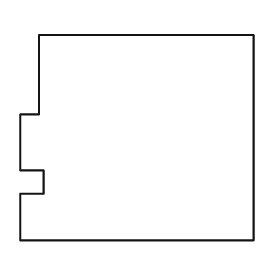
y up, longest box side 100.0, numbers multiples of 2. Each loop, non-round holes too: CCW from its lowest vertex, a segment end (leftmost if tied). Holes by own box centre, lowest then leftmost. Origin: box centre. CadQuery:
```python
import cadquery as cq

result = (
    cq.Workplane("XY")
    .moveTo(-50.0, -44.0)
    .lineTo(50.0, -44.0)
    .lineTo(50.0, 44.0)
    .lineTo(-42.0, 44.0)
    .lineTo(-42.0, 10.0)
    .lineTo(-50.0, 10.0)
    .lineTo(-50.0, -14.0)
    .lineTo(-40.0, -14.0)
    .lineTo(-40.0, -24.0)
    .lineTo(-50.0, -24.0)
    .close()
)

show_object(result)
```